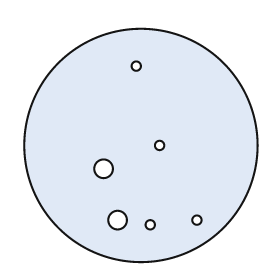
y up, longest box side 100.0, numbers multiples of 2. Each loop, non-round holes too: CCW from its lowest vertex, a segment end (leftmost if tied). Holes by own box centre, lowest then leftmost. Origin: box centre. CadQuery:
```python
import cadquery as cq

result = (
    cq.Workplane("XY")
    .moveTo(0.0, 0.0)
    .circle(50.0)
    .moveTo(4.0, -34.0)
    .circle(2.0)
    .moveTo(-10.0, -32.0)
    .circle(4.0)
    .moveTo(24.0, -32.0)
    .circle(2.0)
    .moveTo(-16.0, -10.0)
    .circle(4.0)
    .moveTo(8.0, 0.0)
    .circle(2.0)
    .moveTo(-2.0, 34.0)
    .circle(2.0)
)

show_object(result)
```